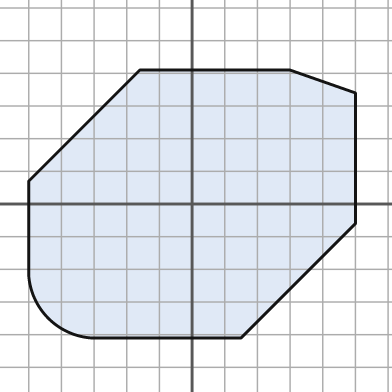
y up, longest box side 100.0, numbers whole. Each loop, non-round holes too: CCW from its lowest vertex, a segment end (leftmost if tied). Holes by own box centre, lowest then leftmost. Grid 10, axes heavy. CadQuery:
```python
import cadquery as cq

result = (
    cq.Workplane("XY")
    .moveTo(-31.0, -41.0)
    .lineTo(15.0, -41.0)
    .lineTo(50.0, -6.0)
    .lineTo(50.0, 34.0)
    .lineTo(30.0, 41.0)
    .lineTo(-16.0, 41.0)
    .lineTo(-50.0, 7.0)
    .lineTo(-50.0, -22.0)
    .threePointArc((-44.0, -35.0), (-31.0, -41.0))
    .close()
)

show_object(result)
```